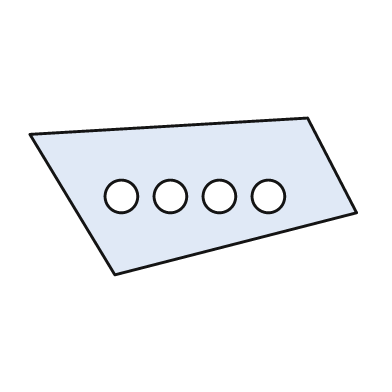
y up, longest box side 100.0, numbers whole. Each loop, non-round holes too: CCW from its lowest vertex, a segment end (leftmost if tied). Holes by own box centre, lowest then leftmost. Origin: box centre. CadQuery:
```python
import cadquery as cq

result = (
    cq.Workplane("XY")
    .moveTo(-24.0, -24.0)
    .lineTo(50.0, -5.0)
    .lineTo(35.0, 24.0)
    .lineTo(-50.0, 19.0)
    .close()
    .moveTo(-22.0, 0.0)
    .circle(5.0)
    .moveTo(-7.0, 0.0)
    .circle(5.0)
    .moveTo(8.0, 0.0)
    .circle(5.0)
    .moveTo(23.0, 0.0)
    .circle(5.0)
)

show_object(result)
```